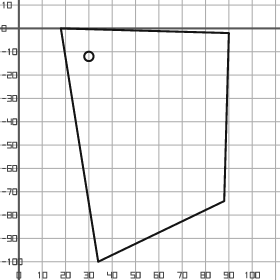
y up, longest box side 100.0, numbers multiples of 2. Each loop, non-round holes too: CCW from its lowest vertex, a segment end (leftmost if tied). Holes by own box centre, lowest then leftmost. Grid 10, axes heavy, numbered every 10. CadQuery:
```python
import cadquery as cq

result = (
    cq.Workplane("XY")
    .moveTo(34.0, -100.0)
    .lineTo(88.0, -74.0)
    .lineTo(90.0, -2.0)
    .lineTo(18.0, 0.0)
    .close()
    .moveTo(30.0, -12.0)
    .circle(2.0)
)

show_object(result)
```